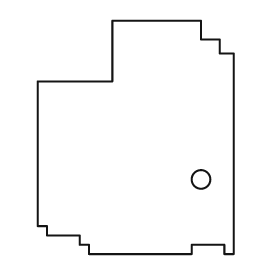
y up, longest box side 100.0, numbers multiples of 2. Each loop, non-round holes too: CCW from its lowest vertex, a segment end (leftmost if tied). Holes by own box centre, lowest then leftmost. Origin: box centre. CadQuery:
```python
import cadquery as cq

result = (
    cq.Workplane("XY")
    .moveTo(-20.0, -50.0)
    .lineTo(24.0, -50.0)
    .lineTo(24.0, -46.0)
    .lineTo(38.0, -46.0)
    .lineTo(38.0, -50.0)
    .lineTo(42.0, -50.0)
    .lineTo(42.0, 36.0)
    .lineTo(36.0, 36.0)
    .lineTo(36.0, 42.0)
    .lineTo(28.0, 42.0)
    .lineTo(28.0, 50.0)
    .lineTo(-10.0, 50.0)
    .lineTo(-10.0, 24.0)
    .lineTo(-42.0, 24.0)
    .lineTo(-42.0, -38.0)
    .lineTo(-38.0, -38.0)
    .lineTo(-38.0, -42.0)
    .lineTo(-24.0, -42.0)
    .lineTo(-24.0, -46.0)
    .lineTo(-20.0, -46.0)
    .close()
    .moveTo(28.0, -18.0)
    .circle(4.0)
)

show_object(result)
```